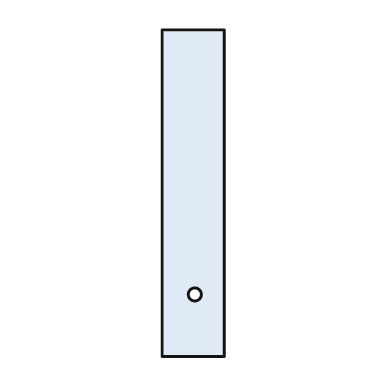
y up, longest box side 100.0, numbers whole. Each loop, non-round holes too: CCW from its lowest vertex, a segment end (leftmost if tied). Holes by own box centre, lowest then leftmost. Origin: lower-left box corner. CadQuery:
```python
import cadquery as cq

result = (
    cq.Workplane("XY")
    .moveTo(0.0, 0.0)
    .lineTo(19.0, 0.0)
    .lineTo(19.0, 100.0)
    .lineTo(0.0, 100.0)
    .close()
    .moveTo(10.0, 19.0)
    .circle(2.0)
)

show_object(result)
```